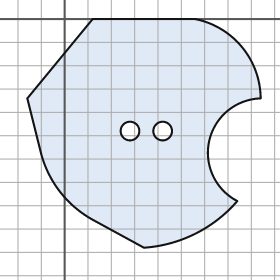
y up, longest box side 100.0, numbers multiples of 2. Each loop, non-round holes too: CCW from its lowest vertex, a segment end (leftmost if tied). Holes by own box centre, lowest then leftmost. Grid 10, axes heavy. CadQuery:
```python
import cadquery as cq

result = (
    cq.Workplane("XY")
    .moveTo(34.0, -98.0)
    .threePointArc((56.0, -92.0), (74.0, -78.0))
    .threePointArc((62.0, -52.0), (84.0, -34.0))
    .threePointArc((76.0, -12.0), (56.0, 0.0))
    .lineTo(12.0, 0.0)
    .lineTo(-16.0, -34.0)
    .lineTo(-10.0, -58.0)
    .threePointArc((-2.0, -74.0), (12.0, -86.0))
    .close()
    .moveTo(28.0, -48.0)
    .circle(4.0)
    .moveTo(42.0, -48.0)
    .circle(4.0)
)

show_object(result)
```